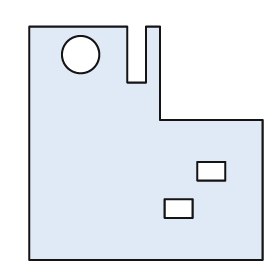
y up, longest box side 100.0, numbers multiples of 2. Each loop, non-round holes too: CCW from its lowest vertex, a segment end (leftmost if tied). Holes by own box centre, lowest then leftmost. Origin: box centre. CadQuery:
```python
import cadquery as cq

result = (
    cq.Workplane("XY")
    .moveTo(-50.0, -50.0)
    .lineTo(50.0, -50.0)
    .lineTo(50.0, 10.0)
    .lineTo(6.0, 10.0)
    .lineTo(6.0, 50.0)
    .lineTo(0.0, 50.0)
    .lineTo(0.0, 26.0)
    .lineTo(-8.0, 26.0)
    .lineTo(-8.0, 50.0)
    .lineTo(-50.0, 50.0)
    .close()
    .moveTo(8.0, -32.0)
    .lineTo(20.0, -32.0)
    .lineTo(20.0, -24.0)
    .lineTo(8.0, -24.0)
    .close()
    .moveTo(22.0, -16.0)
    .lineTo(34.0, -16.0)
    .lineTo(34.0, -8.0)
    .lineTo(22.0, -8.0)
    .close()
    .moveTo(-28.0, 38.0)
    .circle(8.0)
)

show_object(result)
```